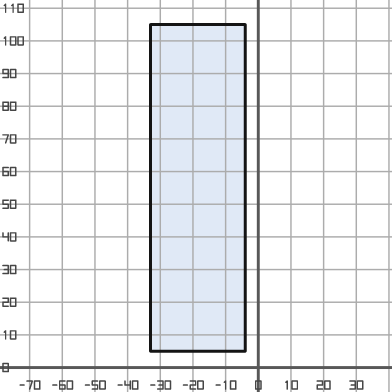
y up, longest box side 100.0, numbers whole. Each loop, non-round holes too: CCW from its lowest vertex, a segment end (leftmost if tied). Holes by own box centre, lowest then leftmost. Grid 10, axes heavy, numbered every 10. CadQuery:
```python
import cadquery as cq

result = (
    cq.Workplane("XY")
    .moveTo(-33.0, 5.0)
    .lineTo(-4.0, 5.0)
    .lineTo(-4.0, 105.0)
    .lineTo(-33.0, 105.0)
    .close()
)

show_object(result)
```